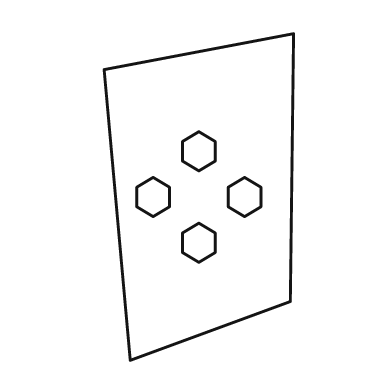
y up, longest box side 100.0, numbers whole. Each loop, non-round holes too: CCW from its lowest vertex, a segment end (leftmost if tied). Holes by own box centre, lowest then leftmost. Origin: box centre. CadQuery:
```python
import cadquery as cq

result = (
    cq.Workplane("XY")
    .moveTo(-21.0, -50.0)
    .lineTo(28.0, -32.0)
    .lineTo(29.0, 50.0)
    .lineTo(-29.0, 39.0)
    .close()
    .moveTo(0.0, -20.0)
    .lineTo(5.0, -17.0)
    .lineTo(5.0, -11.0)
    .lineTo(0.0, -8.0)
    .lineTo(-5.0, -11.0)
    .lineTo(-5.0, -17.0)
    .close()
    .moveTo(-14.0, -6.0)
    .lineTo(-9.0, -3.0)
    .lineTo(-9.0, 3.0)
    .lineTo(-14.0, 6.0)
    .lineTo(-19.0, 3.0)
    .lineTo(-19.0, -3.0)
    .close()
    .moveTo(14.0, -6.0)
    .lineTo(19.0, -3.0)
    .lineTo(19.0, 3.0)
    .lineTo(14.0, 6.0)
    .lineTo(9.0, 3.0)
    .lineTo(9.0, -3.0)
    .close()
    .moveTo(0.0, 8.0)
    .lineTo(5.0, 11.0)
    .lineTo(5.0, 17.0)
    .lineTo(0.0, 20.0)
    .lineTo(-5.0, 17.0)
    .lineTo(-5.0, 11.0)
    .close()
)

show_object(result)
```